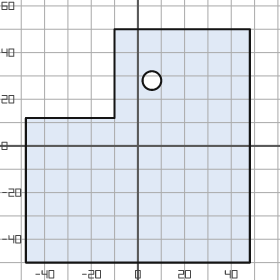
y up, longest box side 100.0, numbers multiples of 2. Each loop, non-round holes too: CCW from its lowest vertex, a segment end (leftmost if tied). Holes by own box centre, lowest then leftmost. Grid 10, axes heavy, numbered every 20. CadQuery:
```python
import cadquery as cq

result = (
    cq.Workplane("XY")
    .moveTo(-48.0, -50.0)
    .lineTo(48.0, -50.0)
    .lineTo(48.0, 50.0)
    .lineTo(-10.0, 50.0)
    .lineTo(-10.0, 12.0)
    .lineTo(-48.0, 12.0)
    .close()
    .moveTo(6.0, 28.0)
    .circle(4.0)
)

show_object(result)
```